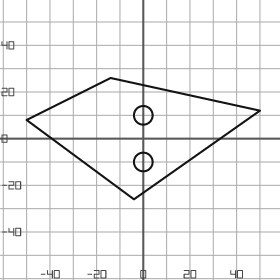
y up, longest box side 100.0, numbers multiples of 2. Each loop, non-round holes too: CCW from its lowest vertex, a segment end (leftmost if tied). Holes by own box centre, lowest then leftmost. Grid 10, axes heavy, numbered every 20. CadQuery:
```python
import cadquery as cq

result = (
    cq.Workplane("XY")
    .moveTo(-4.0, -26.0)
    .lineTo(50.0, 12.0)
    .lineTo(-14.0, 26.0)
    .lineTo(-50.0, 8.0)
    .close()
    .moveTo(0.0, -10.0)
    .circle(4.0)
    .moveTo(0.0, 10.0)
    .circle(4.0)
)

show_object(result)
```